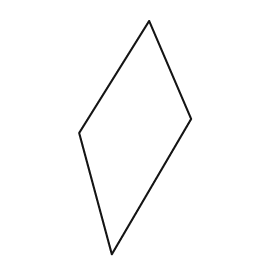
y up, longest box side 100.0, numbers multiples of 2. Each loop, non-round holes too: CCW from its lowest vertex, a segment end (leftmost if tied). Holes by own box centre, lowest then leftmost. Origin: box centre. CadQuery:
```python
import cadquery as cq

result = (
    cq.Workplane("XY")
    .moveTo(-10.0, -50.0)
    .lineTo(24.0, 8.0)
    .lineTo(6.0, 50.0)
    .lineTo(-24.0, 2.0)
    .close()
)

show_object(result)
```